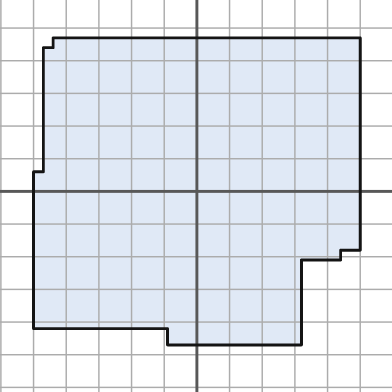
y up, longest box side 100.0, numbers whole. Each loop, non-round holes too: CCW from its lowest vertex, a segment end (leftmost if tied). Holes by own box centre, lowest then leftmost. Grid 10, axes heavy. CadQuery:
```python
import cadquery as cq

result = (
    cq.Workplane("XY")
    .moveTo(-9.0, -47.0)
    .lineTo(32.0, -47.0)
    .lineTo(32.0, -21.0)
    .lineTo(44.0, -21.0)
    .lineTo(44.0, -18.0)
    .lineTo(50.0, -18.0)
    .lineTo(50.0, 47.0)
    .lineTo(-44.0, 47.0)
    .lineTo(-44.0, 44.0)
    .lineTo(-47.0, 44.0)
    .lineTo(-47.0, 6.0)
    .lineTo(-50.0, 6.0)
    .lineTo(-50.0, -42.0)
    .lineTo(-9.0, -42.0)
    .close()
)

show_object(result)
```